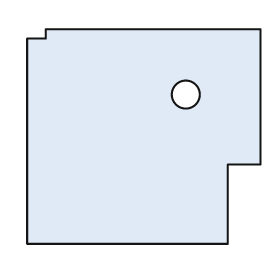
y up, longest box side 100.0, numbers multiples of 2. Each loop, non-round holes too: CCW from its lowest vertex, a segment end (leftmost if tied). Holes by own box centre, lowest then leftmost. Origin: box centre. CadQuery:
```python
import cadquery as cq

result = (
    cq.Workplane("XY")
    .moveTo(-50.0, -46.0)
    .lineTo(36.0, -46.0)
    .lineTo(36.0, -12.0)
    .lineTo(50.0, -12.0)
    .lineTo(50.0, 46.0)
    .lineTo(-42.0, 46.0)
    .lineTo(-42.0, 42.0)
    .lineTo(-50.0, 42.0)
    .close()
    .moveTo(18.0, 18.0)
    .circle(6.0)
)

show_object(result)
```